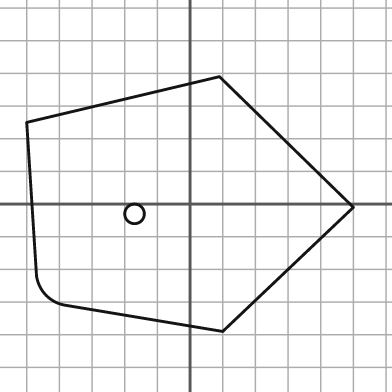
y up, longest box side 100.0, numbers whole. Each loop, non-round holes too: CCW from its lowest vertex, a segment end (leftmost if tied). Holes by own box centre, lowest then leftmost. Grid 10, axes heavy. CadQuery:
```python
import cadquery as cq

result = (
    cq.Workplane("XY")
    .moveTo(10.0, -39.0)
    .lineTo(50.0, -1.0)
    .lineTo(9.0, 39.0)
    .lineTo(-50.0, 25.0)
    .lineTo(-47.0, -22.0)
    .threePointArc((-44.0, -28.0), (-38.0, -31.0))
    .close()
    .moveTo(-17.0, -3.0)
    .circle(3.0)
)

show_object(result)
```